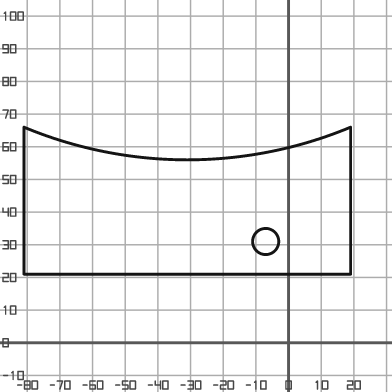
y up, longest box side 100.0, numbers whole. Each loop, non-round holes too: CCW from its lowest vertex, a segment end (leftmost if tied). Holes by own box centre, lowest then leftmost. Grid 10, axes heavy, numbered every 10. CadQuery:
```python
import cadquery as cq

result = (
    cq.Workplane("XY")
    .moveTo(-81.0, 21.0)
    .lineTo(19.0, 21.0)
    .lineTo(19.0, 66.0)
    .threePointArc((-31.0, 56.0), (-81.0, 66.0))
    .close()
    .moveTo(-7.0, 31.0)
    .circle(4.0)
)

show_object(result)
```